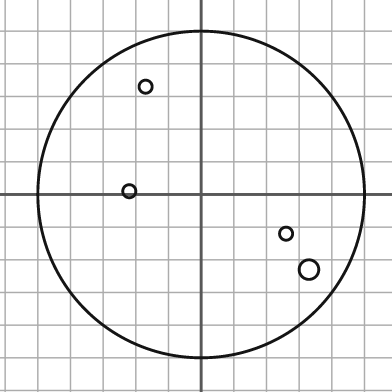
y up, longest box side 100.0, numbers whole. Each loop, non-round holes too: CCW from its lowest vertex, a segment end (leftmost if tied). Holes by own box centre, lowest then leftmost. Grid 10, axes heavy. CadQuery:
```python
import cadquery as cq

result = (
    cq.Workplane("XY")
    .moveTo(0.0, 0.0)
    .circle(50.0)
    .moveTo(33.0, -23.0)
    .circle(3.0)
    .moveTo(26.0, -12.0)
    .circle(2.0)
    .moveTo(-22.0, 1.0)
    .circle(2.0)
    .moveTo(-17.0, 33.0)
    .circle(2.0)
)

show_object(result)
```